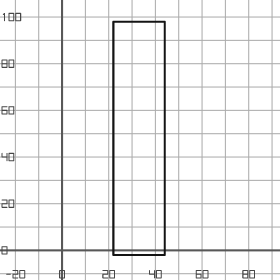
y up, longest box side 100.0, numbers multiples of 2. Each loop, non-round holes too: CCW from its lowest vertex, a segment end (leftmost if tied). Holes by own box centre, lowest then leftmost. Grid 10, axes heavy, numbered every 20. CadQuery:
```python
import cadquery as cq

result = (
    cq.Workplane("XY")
    .moveTo(22.0, -2.0)
    .lineTo(44.0, -2.0)
    .lineTo(44.0, 98.0)
    .lineTo(22.0, 98.0)
    .close()
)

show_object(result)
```